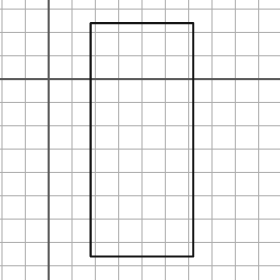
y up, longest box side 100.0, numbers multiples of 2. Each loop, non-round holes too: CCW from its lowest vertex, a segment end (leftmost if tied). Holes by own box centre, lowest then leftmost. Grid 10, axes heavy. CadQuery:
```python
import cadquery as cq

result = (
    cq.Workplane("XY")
    .moveTo(18.0, -76.0)
    .lineTo(62.0, -76.0)
    .lineTo(62.0, 24.0)
    .lineTo(18.0, 24.0)
    .close()
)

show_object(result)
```